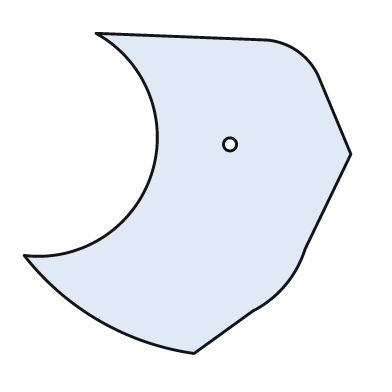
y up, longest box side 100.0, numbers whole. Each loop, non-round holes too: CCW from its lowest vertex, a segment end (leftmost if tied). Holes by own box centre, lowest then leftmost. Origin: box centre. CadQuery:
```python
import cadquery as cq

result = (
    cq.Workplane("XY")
    .moveTo(2.0, -49.0)
    .lineTo(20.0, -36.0)
    .threePointArc((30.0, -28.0), (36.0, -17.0))
    .lineTo(50.0, 12.0)
    .lineTo(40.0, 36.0)
    .threePointArc((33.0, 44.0), (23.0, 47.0))
    .lineTo(-28.0, 49.0)
    .threePointArc((-11.0, 6.0), (-50.0, -19.0))
    .threePointArc((-27.0, -39.0), (2.0, -49.0))
    .close()
    .moveTo(13.0, 15.0)
    .circle(2.0)
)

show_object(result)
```